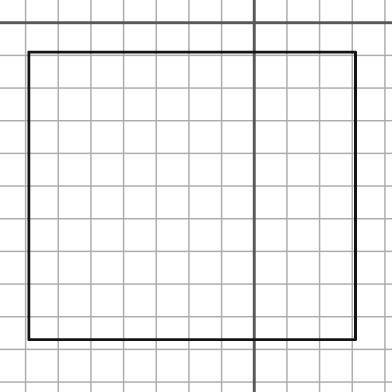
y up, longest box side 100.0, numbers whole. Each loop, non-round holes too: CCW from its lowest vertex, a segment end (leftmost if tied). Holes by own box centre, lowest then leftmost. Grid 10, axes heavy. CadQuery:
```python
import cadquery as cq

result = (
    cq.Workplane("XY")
    .moveTo(-69.0, -97.0)
    .lineTo(31.0, -97.0)
    .lineTo(31.0, -9.0)
    .lineTo(-69.0, -9.0)
    .close()
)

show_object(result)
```